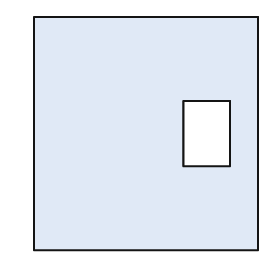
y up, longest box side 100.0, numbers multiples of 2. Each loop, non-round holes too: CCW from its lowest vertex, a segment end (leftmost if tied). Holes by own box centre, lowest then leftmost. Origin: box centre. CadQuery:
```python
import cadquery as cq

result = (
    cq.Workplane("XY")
    .moveTo(-48.0, -50.0)
    .lineTo(48.0, -50.0)
    .lineTo(48.0, 50.0)
    .lineTo(-48.0, 50.0)
    .close()
    .moveTo(16.0, -14.0)
    .lineTo(36.0, -14.0)
    .lineTo(36.0, 14.0)
    .lineTo(16.0, 14.0)
    .close()
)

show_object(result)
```